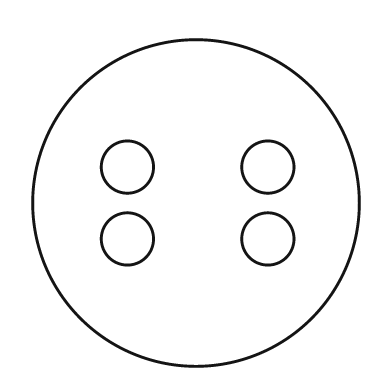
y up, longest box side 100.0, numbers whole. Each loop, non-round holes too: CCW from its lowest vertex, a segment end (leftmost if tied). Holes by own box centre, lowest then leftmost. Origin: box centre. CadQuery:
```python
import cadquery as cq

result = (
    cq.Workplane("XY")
    .moveTo(0.0, 0.0)
    .circle(50.0)
    .moveTo(-21.0, -11.0)
    .circle(8.0)
    .moveTo(22.0, -11.0)
    .circle(8.0)
    .moveTo(-21.0, 11.0)
    .circle(8.0)
    .moveTo(22.0, 11.0)
    .circle(8.0)
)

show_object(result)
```